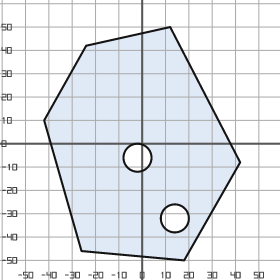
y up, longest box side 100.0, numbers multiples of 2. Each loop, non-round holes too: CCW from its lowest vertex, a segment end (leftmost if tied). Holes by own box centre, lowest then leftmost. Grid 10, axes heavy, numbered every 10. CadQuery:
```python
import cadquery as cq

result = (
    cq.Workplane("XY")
    .moveTo(18.0, -50.0)
    .lineTo(42.0, -8.0)
    .lineTo(12.0, 50.0)
    .lineTo(-24.0, 42.0)
    .lineTo(-42.0, 10.0)
    .lineTo(-26.0, -46.0)
    .close()
    .moveTo(14.0, -32.0)
    .circle(6.0)
    .moveTo(-2.0, -6.0)
    .circle(6.0)
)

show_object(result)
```